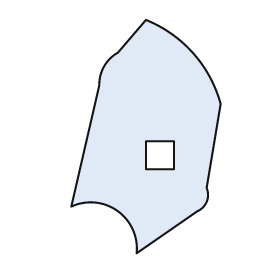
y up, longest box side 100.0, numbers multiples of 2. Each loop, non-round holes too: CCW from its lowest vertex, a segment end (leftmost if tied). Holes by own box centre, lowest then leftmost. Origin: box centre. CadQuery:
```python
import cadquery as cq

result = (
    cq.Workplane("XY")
    .moveTo(-4.0, -50.0)
    .lineTo(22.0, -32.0)
    .threePointArc((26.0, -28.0), (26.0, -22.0))
    .lineTo(32.0, 14.0)
    .threePointArc((20.0, 36.0), (0.0, 50.0))
    .lineTo(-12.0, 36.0)
    .threePointArc((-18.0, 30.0), (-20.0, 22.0))
    .lineTo(-32.0, -30.0)
    .threePointArc((-12.0, -32.0), (-4.0, -50.0))
    .close()
    .moveTo(0.0, -14.0)
    .lineTo(12.0, -14.0)
    .lineTo(12.0, -2.0)
    .lineTo(0.0, -2.0)
    .close()
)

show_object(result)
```